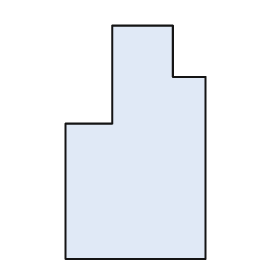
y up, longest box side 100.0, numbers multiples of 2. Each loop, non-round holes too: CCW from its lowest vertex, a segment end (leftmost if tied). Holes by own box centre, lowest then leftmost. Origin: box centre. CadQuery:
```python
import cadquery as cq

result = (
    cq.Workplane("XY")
    .moveTo(-30.0, -50.0)
    .lineTo(30.0, -50.0)
    .lineTo(30.0, 28.0)
    .lineTo(16.0, 28.0)
    .lineTo(16.0, 50.0)
    .lineTo(-10.0, 50.0)
    .lineTo(-10.0, 8.0)
    .lineTo(-30.0, 8.0)
    .close()
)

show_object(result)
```